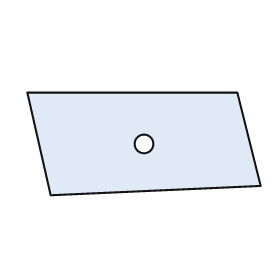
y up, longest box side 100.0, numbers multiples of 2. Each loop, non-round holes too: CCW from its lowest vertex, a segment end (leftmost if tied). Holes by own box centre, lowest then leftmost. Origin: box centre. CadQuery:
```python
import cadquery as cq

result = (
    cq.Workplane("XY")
    .moveTo(-40.0, -22.0)
    .lineTo(50.0, -18.0)
    .lineTo(40.0, 22.0)
    .lineTo(-50.0, 22.0)
    .close()
    .moveTo(0.0, 0.0)
    .circle(4.0)
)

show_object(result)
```